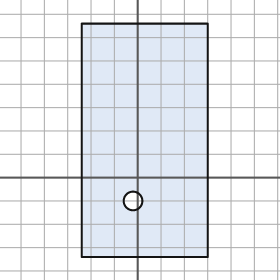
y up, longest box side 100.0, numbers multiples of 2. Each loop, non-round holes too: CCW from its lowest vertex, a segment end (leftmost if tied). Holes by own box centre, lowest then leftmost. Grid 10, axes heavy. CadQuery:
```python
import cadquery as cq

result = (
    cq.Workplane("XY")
    .moveTo(-24.0, -34.0)
    .lineTo(30.0, -34.0)
    .lineTo(30.0, 66.0)
    .lineTo(-24.0, 66.0)
    .close()
    .moveTo(-2.0, -10.0)
    .circle(4.0)
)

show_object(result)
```